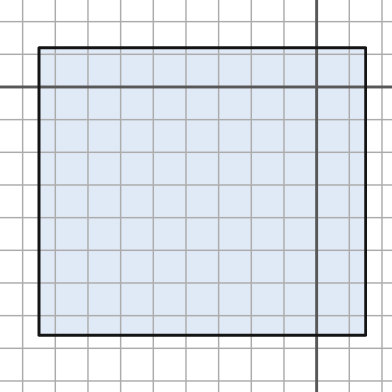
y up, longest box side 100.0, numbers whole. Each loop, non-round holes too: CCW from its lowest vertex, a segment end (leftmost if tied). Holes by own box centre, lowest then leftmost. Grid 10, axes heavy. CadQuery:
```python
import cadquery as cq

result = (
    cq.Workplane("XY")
    .moveTo(-85.0, -76.0)
    .lineTo(15.0, -76.0)
    .lineTo(15.0, 12.0)
    .lineTo(-85.0, 12.0)
    .close()
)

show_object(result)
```